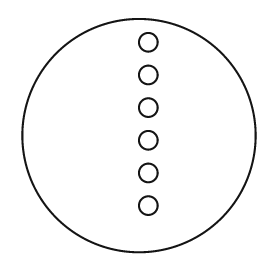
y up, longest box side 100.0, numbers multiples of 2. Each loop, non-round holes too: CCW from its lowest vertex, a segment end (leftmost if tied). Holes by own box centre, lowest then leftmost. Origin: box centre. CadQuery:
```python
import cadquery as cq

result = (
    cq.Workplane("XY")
    .moveTo(0.0, 0.0)
    .circle(50.0)
    .moveTo(4.0, -30.0)
    .circle(4.0)
    .moveTo(4.0, -16.0)
    .circle(4.0)
    .moveTo(4.0, -2.0)
    .circle(4.0)
    .moveTo(4.0, 12.0)
    .circle(4.0)
    .moveTo(4.0, 26.0)
    .circle(4.0)
    .moveTo(4.0, 40.0)
    .circle(4.0)
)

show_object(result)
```